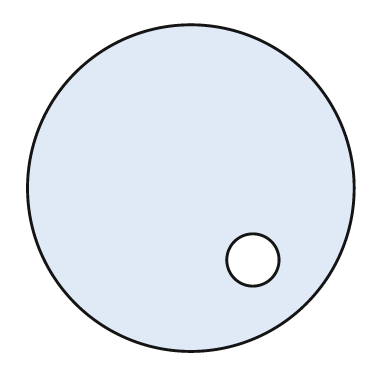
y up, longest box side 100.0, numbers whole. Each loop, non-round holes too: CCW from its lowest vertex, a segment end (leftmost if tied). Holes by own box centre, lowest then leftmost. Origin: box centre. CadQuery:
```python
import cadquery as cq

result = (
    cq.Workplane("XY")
    .moveTo(0.0, 0.0)
    .circle(50.0)
    .moveTo(19.0, -22.0)
    .circle(8.0)
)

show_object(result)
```